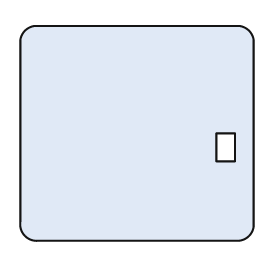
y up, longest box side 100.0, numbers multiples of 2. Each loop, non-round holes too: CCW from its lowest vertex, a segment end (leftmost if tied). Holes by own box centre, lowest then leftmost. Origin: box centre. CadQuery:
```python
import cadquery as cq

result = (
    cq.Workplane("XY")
    .moveTo(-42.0, -46.0)
    .lineTo(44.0, -46.0)
    .threePointArc((48.0, -44.0), (50.0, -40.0))
    .lineTo(50.0, 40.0)
    .threePointArc((48.0, 44.0), (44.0, 46.0))
    .lineTo(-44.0, 46.0)
    .threePointArc((-48.0, 44.0), (-50.0, 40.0))
    .lineTo(-50.0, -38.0)
    .threePointArc((-48.0, -44.0), (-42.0, -46.0))
    .close()
    .moveTo(34.0, -12.0)
    .lineTo(42.0, -12.0)
    .lineTo(42.0, 0.0)
    .lineTo(34.0, 0.0)
    .close()
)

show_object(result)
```